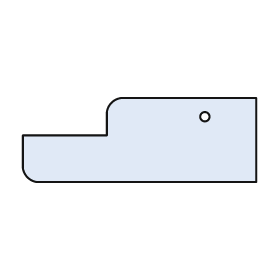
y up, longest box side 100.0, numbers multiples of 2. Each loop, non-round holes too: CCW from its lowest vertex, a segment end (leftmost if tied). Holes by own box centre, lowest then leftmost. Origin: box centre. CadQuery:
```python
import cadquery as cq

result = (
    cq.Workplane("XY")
    .moveTo(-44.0, -18.0)
    .lineTo(50.0, -18.0)
    .lineTo(50.0, 18.0)
    .lineTo(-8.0, 18.0)
    .threePointArc((-12.0, 16.0), (-14.0, 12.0))
    .lineTo(-14.0, 2.0)
    .lineTo(-50.0, 2.0)
    .lineTo(-50.0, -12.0)
    .threePointArc((-48.0, -16.0), (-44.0, -18.0))
    .close()
    .moveTo(28.0, 10.0)
    .circle(2.0)
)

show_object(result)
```